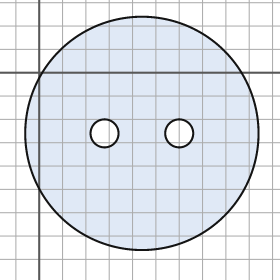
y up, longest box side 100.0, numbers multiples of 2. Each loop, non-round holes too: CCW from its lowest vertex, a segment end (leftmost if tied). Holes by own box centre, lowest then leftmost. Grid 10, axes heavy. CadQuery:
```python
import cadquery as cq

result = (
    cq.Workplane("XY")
    .moveTo(44.0, -26.0)
    .circle(50.0)
    .moveTo(28.0, -26.0)
    .circle(6.0)
    .moveTo(60.0, -26.0)
    .circle(6.0)
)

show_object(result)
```